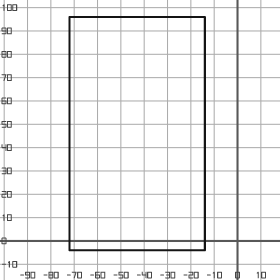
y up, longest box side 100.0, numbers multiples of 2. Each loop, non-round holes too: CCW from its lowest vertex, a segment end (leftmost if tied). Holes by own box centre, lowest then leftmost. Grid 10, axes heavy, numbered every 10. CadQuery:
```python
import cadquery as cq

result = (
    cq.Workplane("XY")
    .moveTo(-72.0, -4.0)
    .lineTo(-14.0, -4.0)
    .lineTo(-14.0, 96.0)
    .lineTo(-72.0, 96.0)
    .close()
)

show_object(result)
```